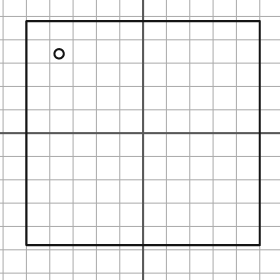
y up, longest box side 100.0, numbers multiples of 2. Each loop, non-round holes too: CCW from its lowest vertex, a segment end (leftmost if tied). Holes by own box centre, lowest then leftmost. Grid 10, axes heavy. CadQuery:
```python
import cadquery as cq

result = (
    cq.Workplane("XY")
    .moveTo(-50.0, -48.0)
    .lineTo(50.0, -48.0)
    .lineTo(50.0, 48.0)
    .lineTo(-50.0, 48.0)
    .close()
    .moveTo(-36.0, 34.0)
    .circle(2.0)
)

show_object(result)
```